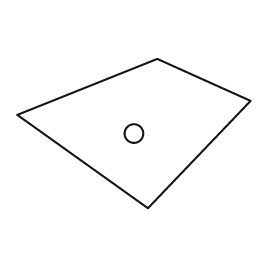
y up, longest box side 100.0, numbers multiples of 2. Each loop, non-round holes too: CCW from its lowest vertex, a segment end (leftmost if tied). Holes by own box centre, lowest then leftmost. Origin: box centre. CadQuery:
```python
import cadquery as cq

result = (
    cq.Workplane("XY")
    .moveTo(6.0, -32.0)
    .lineTo(50.0, 14.0)
    .lineTo(10.0, 32.0)
    .lineTo(-50.0, 8.0)
    .close()
    .moveTo(0.0, 0.0)
    .circle(4.0)
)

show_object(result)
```